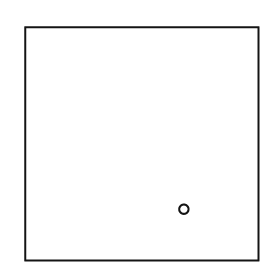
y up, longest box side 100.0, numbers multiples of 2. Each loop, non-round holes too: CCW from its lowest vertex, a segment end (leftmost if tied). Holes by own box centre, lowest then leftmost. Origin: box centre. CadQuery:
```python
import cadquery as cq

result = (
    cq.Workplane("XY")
    .moveTo(-50.0, -50.0)
    .lineTo(50.0, -50.0)
    .lineTo(50.0, 50.0)
    .lineTo(-50.0, 50.0)
    .close()
    .moveTo(18.0, -28.0)
    .circle(2.0)
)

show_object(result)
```